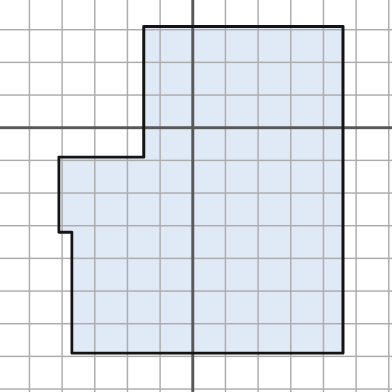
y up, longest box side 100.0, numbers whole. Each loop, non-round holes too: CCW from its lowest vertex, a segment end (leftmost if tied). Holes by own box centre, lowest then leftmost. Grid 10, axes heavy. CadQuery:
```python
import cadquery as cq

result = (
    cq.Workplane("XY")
    .moveTo(-37.0, -69.0)
    .lineTo(46.0, -69.0)
    .lineTo(46.0, 31.0)
    .lineTo(-15.0, 31.0)
    .lineTo(-15.0, -9.0)
    .lineTo(-41.0, -9.0)
    .lineTo(-41.0, -32.0)
    .lineTo(-37.0, -32.0)
    .close()
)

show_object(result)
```